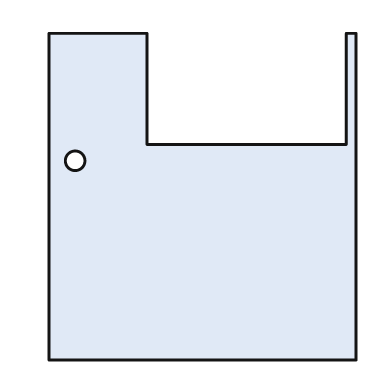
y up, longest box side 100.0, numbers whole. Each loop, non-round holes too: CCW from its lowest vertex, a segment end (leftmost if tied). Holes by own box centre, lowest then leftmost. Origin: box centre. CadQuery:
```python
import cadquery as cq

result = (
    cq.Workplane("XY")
    .moveTo(-47.0, -50.0)
    .lineTo(47.0, -50.0)
    .lineTo(47.0, 50.0)
    .lineTo(44.0, 50.0)
    .lineTo(44.0, 16.0)
    .lineTo(-17.0, 16.0)
    .lineTo(-17.0, 50.0)
    .lineTo(-47.0, 50.0)
    .close()
    .moveTo(-39.0, 11.0)
    .circle(3.0)
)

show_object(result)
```